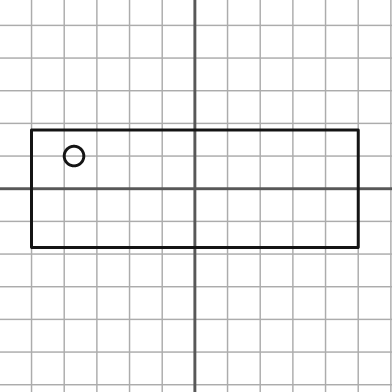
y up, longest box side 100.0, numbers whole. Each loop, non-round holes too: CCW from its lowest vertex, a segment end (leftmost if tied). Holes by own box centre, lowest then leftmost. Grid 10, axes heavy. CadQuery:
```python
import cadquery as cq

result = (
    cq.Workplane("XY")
    .moveTo(-50.0, -18.0)
    .lineTo(50.0, -18.0)
    .lineTo(50.0, 18.0)
    .lineTo(-50.0, 18.0)
    .close()
    .moveTo(-37.0, 10.0)
    .circle(3.0)
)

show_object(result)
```